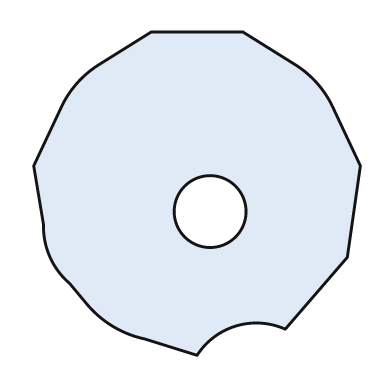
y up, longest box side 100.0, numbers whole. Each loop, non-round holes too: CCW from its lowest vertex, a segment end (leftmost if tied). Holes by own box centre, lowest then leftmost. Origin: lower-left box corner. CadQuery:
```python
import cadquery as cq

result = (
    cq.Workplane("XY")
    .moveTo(50.0, 0.0)
    .threePointArc((62.0, 9.0), (77.0, 8.0))
    .lineTo(96.0, 30.0)
    .lineTo(100.0, 58.0)
    .lineTo(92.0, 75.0)
    .threePointArc((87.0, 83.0), (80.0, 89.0))
    .lineTo(64.0, 99.0)
    .lineTo(36.0, 99.0)
    .lineTo(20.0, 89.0)
    .threePointArc((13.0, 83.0), (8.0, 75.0))
    .lineTo(0.0, 58.0)
    .lineTo(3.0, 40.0)
    .threePointArc((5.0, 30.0), (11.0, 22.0))
    .lineTo(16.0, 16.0)
    .threePointArc((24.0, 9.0), (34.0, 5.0))
    .close()
    .moveTo(54.0, 44.0)
    .circle(11.0)
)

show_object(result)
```